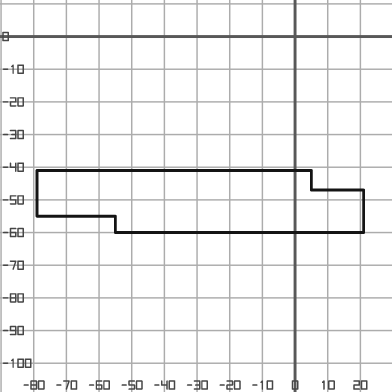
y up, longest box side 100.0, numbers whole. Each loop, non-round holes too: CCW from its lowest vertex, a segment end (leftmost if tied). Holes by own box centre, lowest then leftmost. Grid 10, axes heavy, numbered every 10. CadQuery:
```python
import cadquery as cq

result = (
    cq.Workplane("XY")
    .moveTo(-55.0, -60.0)
    .lineTo(21.0, -60.0)
    .lineTo(21.0, -47.0)
    .lineTo(5.0, -47.0)
    .lineTo(5.0, -41.0)
    .lineTo(-79.0, -41.0)
    .lineTo(-79.0, -55.0)
    .lineTo(-55.0, -55.0)
    .close()
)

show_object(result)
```